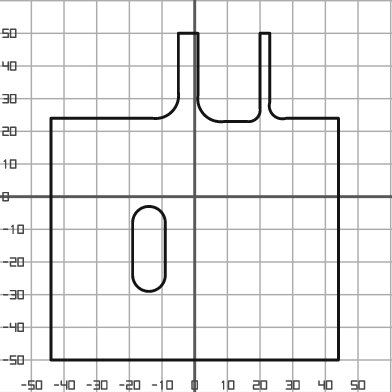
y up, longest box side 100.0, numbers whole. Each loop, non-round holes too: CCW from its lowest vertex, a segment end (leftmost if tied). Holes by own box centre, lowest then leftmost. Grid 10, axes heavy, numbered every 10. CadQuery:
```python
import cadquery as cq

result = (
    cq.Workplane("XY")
    .moveTo(-44.0, -50.0)
    .lineTo(44.0, -50.0)
    .lineTo(44.0, 24.0)
    .lineTo(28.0, 24.0)
    .threePointArc((24.0, 25.0), (23.0, 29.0))
    .lineTo(23.0, 50.0)
    .lineTo(20.0, 50.0)
    .lineTo(20.0, 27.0)
    .threePointArc((19.0, 24.0), (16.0, 23.0))
    .lineTo(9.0, 23.0)
    .threePointArc((3.0, 25.0), (1.0, 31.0))
    .lineTo(1.0, 50.0)
    .lineTo(-5.0, 50.0)
    .lineTo(-5.0, 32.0)
    .threePointArc((-7.0, 26.0), (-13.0, 24.0))
    .lineTo(-44.0, 24.0)
    .close()
    .moveTo(-19.0, -24.0)
    .threePointArc((-14.0, -29.0), (-9.0, -24.0))
    .lineTo(-9.0, -8.0)
    .threePointArc((-14.0, -3.0), (-19.0, -8.0))
    .close()
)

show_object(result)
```